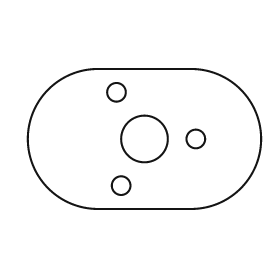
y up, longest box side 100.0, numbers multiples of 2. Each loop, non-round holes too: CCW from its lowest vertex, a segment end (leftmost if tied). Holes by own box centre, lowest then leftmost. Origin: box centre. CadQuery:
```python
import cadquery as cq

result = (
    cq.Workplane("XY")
    .moveTo(-20.0, -30.0)
    .lineTo(20.0, -30.0)
    .threePointArc((50.0, 0.0), (20.0, 30.0))
    .lineTo(-20.0, 30.0)
    .threePointArc((-50.0, 0.0), (-20.0, -30.0))
    .close()
    .moveTo(-10.0, -20.0)
    .circle(4.0)
    .moveTo(0.0, 0.0)
    .circle(10.0)
    .moveTo(22.0, 0.0)
    .circle(4.0)
    .moveTo(-12.0, 20.0)
    .circle(4.0)
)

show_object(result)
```